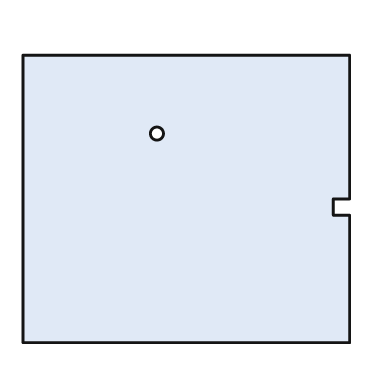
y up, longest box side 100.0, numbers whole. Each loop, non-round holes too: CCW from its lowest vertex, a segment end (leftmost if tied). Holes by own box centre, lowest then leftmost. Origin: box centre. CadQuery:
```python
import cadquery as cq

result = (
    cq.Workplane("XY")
    .moveTo(-50.0, -44.0)
    .lineTo(50.0, -44.0)
    .lineTo(50.0, -5.0)
    .lineTo(45.0, -5.0)
    .lineTo(45.0, 0.0)
    .lineTo(50.0, 0.0)
    .lineTo(50.0, 44.0)
    .lineTo(-50.0, 44.0)
    .close()
    .moveTo(-9.0, 20.0)
    .circle(2.0)
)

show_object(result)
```